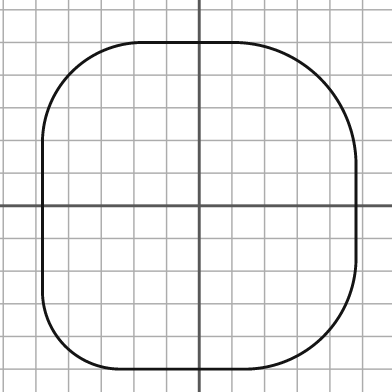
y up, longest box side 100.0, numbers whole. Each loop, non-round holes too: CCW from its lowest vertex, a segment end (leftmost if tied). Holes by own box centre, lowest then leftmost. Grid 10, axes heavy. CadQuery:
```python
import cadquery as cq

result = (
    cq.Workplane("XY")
    .moveTo(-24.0, -50.0)
    .lineTo(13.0, -50.0)
    .threePointArc((38.0, -40.0), (48.0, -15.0))
    .lineTo(48.0, 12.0)
    .threePointArc((37.0, 39.0), (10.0, 50.0))
    .lineTo(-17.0, 50.0)
    .threePointArc((-39.0, 41.0), (-48.0, 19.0))
    .lineTo(-48.0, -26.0)
    .threePointArc((-41.0, -43.0), (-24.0, -50.0))
    .close()
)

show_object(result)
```